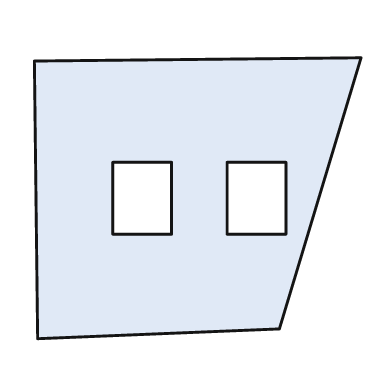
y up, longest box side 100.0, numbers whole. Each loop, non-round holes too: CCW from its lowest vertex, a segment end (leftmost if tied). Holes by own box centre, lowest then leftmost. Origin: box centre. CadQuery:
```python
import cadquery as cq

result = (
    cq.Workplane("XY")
    .moveTo(-49.0, -43.0)
    .lineTo(25.0, -40.0)
    .lineTo(50.0, 43.0)
    .lineTo(-50.0, 42.0)
    .close()
    .moveTo(-26.0, -11.0)
    .lineTo(-8.0, -11.0)
    .lineTo(-8.0, 11.0)
    .lineTo(-26.0, 11.0)
    .close()
    .moveTo(9.0, -11.0)
    .lineTo(27.0, -11.0)
    .lineTo(27.0, 11.0)
    .lineTo(9.0, 11.0)
    .close()
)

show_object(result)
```